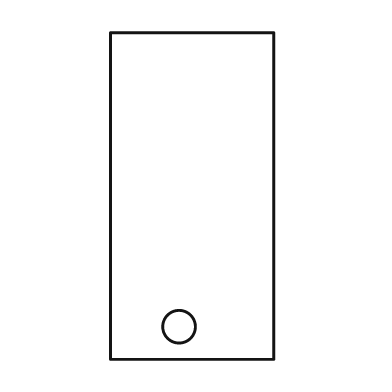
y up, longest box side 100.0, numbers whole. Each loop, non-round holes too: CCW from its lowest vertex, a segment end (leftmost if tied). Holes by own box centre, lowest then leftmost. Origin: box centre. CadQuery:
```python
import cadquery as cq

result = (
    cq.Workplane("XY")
    .moveTo(-25.0, -50.0)
    .lineTo(25.0, -50.0)
    .lineTo(25.0, 50.0)
    .lineTo(-25.0, 50.0)
    .close()
    .moveTo(-4.0, -40.0)
    .circle(5.0)
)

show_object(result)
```